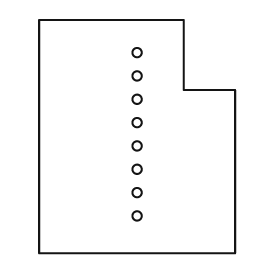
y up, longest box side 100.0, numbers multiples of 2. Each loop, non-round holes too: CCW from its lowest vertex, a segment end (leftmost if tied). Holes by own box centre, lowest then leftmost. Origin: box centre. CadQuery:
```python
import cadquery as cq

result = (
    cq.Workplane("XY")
    .moveTo(-42.0, -50.0)
    .lineTo(42.0, -50.0)
    .lineTo(42.0, 20.0)
    .lineTo(20.0, 20.0)
    .lineTo(20.0, 50.0)
    .lineTo(-42.0, 50.0)
    .close()
    .moveTo(0.0, -34.0)
    .circle(2.0)
    .moveTo(0.0, -24.0)
    .circle(2.0)
    .moveTo(0.0, -14.0)
    .circle(2.0)
    .moveTo(0.0, -4.0)
    .circle(2.0)
    .moveTo(0.0, 6.0)
    .circle(2.0)
    .moveTo(0.0, 16.0)
    .circle(2.0)
    .moveTo(0.0, 26.0)
    .circle(2.0)
    .moveTo(0.0, 36.0)
    .circle(2.0)
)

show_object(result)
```